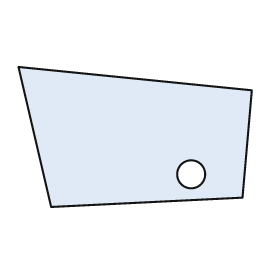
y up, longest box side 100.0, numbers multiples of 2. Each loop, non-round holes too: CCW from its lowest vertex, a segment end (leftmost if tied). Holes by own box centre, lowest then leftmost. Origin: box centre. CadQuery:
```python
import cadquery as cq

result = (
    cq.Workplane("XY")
    .moveTo(-36.0, -30.0)
    .lineTo(46.0, -26.0)
    .lineTo(50.0, 20.0)
    .lineTo(-50.0, 30.0)
    .close()
    .moveTo(24.0, -16.0)
    .circle(6.0)
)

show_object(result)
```